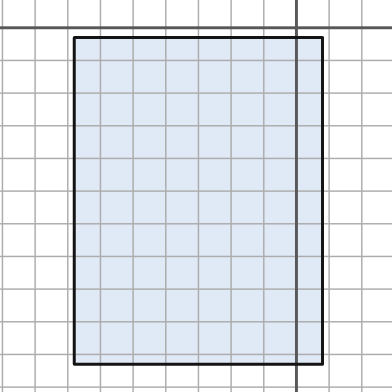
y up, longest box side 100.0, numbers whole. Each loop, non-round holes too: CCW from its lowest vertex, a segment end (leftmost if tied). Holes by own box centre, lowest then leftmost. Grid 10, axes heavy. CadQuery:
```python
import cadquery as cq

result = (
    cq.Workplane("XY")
    .moveTo(-68.0, -103.0)
    .lineTo(8.0, -103.0)
    .lineTo(8.0, -3.0)
    .lineTo(-68.0, -3.0)
    .close()
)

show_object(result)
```